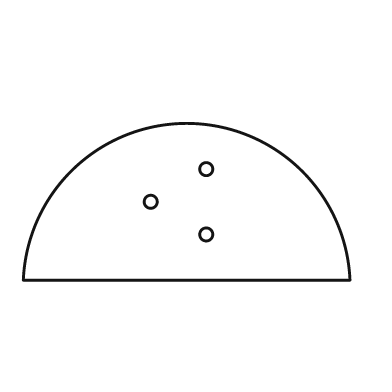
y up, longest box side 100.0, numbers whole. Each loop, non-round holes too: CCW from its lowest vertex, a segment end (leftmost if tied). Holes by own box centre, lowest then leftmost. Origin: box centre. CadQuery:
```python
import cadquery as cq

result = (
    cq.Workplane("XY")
    .moveTo(-50.0, -24.0)
    .lineTo(50.0, -24.0)
    .threePointArc((0.0, 24.0), (-50.0, -24.0))
    .close()
    .moveTo(6.0, -10.0)
    .circle(2.0)
    .moveTo(-11.0, 0.0)
    .circle(2.0)
    .moveTo(6.0, 10.0)
    .circle(2.0)
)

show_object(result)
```